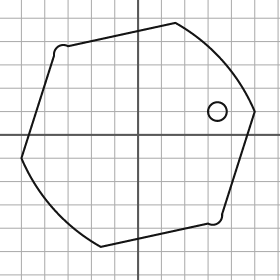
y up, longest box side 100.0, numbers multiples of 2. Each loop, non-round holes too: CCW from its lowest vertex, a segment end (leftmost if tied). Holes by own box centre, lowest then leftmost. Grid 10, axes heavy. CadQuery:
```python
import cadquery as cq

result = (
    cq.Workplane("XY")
    .moveTo(-16.0, -48.0)
    .lineTo(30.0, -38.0)
    .threePointArc((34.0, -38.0), (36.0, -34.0))
    .lineTo(50.0, 10.0)
    .threePointArc((36.0, 32.0), (16.0, 48.0))
    .lineTo(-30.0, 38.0)
    .threePointArc((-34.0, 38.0), (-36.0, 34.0))
    .lineTo(-50.0, -10.0)
    .threePointArc((-36.0, -32.0), (-16.0, -48.0))
    .close()
    .moveTo(34.0, 10.0)
    .circle(4.0)
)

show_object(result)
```